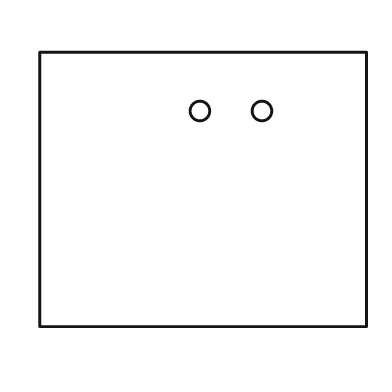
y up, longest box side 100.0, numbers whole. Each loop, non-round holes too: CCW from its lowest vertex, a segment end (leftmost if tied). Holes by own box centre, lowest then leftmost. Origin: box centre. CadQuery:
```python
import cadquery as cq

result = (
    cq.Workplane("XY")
    .moveTo(-50.0, -42.0)
    .lineTo(50.0, -42.0)
    .lineTo(50.0, 42.0)
    .lineTo(-50.0, 42.0)
    .close()
    .moveTo(-1.0, 24.0)
    .circle(3.0)
    .moveTo(18.0, 24.0)
    .circle(3.0)
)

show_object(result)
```